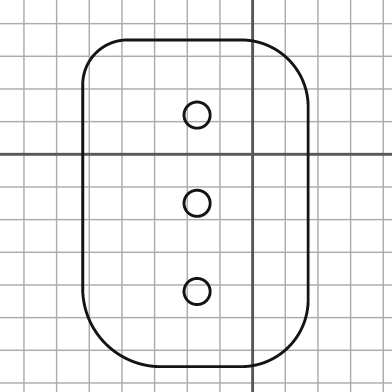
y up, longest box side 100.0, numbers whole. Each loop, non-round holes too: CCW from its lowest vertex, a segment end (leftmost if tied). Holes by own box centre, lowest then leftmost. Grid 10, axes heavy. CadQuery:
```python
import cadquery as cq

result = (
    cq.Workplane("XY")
    .moveTo(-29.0, -65.0)
    .lineTo(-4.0, -65.0)
    .threePointArc((11.0, -59.0), (17.0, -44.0))
    .lineTo(17.0, 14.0)
    .threePointArc((11.0, 29.0), (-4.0, 35.0))
    .lineTo(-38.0, 35.0)
    .threePointArc((-48.0, 31.0), (-52.0, 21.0))
    .lineTo(-52.0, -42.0)
    .threePointArc((-45.0, -58.0), (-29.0, -65.0))
    .close()
    .moveTo(-17.0, -42.0)
    .circle(4.0)
    .moveTo(-17.0, -15.0)
    .circle(4.0)
    .moveTo(-17.0, 12.0)
    .circle(4.0)
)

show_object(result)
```